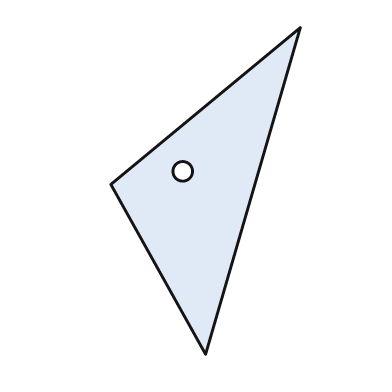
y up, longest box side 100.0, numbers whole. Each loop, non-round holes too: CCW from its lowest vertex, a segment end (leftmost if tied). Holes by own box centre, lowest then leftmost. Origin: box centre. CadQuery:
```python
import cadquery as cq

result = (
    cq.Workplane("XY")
    .moveTo(0.0, -50.0)
    .lineTo(29.0, 50.0)
    .lineTo(-29.0, 2.0)
    .close()
    .moveTo(-7.0, 6.0)
    .circle(3.0)
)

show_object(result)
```